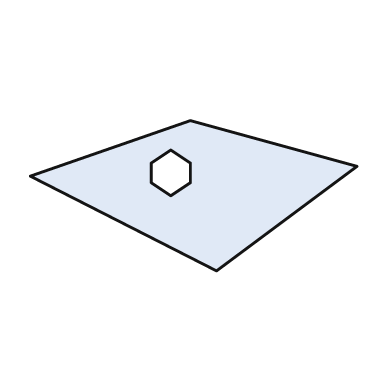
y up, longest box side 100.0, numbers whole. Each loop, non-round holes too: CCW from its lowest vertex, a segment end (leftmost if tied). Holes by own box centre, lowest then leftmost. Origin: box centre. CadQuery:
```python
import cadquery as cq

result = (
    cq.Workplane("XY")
    .moveTo(7.0, -23.0)
    .lineTo(50.0, 9.0)
    .lineTo(-1.0, 23.0)
    .lineTo(-50.0, 6.0)
    .close()
    .moveTo(-7.0, 0.0)
    .lineTo(-1.0, 4.0)
    .lineTo(-1.0, 10.0)
    .lineTo(-7.0, 14.0)
    .lineTo(-13.0, 10.0)
    .lineTo(-13.0, 4.0)
    .close()
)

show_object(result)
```